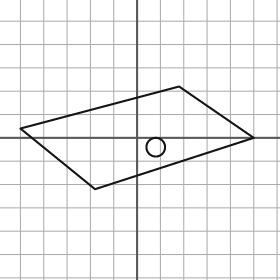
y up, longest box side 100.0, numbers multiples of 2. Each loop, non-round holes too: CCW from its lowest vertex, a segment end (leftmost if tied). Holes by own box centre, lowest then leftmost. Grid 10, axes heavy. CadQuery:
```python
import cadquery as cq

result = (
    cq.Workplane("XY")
    .moveTo(-18.0, -22.0)
    .lineTo(50.0, 0.0)
    .lineTo(18.0, 22.0)
    .lineTo(-50.0, 4.0)
    .close()
    .moveTo(8.0, -4.0)
    .circle(4.0)
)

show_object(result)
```